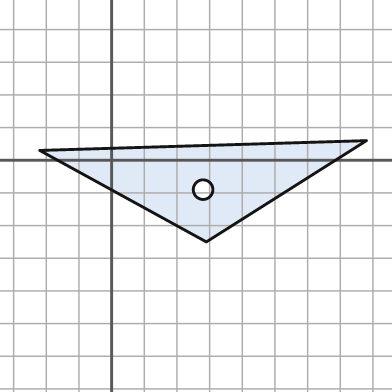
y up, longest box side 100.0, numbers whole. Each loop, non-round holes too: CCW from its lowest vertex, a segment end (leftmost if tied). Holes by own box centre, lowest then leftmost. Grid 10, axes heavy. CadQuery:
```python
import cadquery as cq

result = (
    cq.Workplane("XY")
    .moveTo(29.0, -25.0)
    .lineTo(78.0, 6.0)
    .lineTo(-22.0, 3.0)
    .close()
    .moveTo(28.0, -9.0)
    .circle(3.0)
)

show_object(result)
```